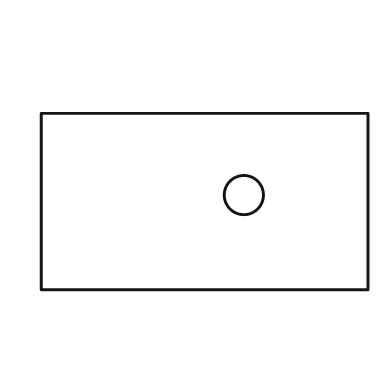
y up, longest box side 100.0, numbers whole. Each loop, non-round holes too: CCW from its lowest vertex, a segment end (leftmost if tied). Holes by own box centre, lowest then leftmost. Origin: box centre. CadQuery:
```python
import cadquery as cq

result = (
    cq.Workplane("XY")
    .moveTo(-50.0, -27.0)
    .lineTo(50.0, -27.0)
    .lineTo(50.0, 27.0)
    .lineTo(-50.0, 27.0)
    .close()
    .moveTo(12.0, 2.0)
    .circle(6.0)
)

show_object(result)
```